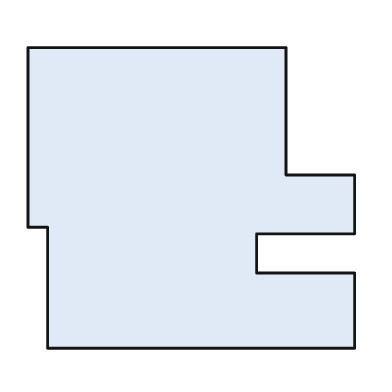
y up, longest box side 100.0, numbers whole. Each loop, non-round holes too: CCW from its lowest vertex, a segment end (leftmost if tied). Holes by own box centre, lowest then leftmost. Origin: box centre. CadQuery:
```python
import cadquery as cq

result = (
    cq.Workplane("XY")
    .moveTo(-44.0, -46.0)
    .lineTo(50.0, -46.0)
    .lineTo(50.0, -23.0)
    .lineTo(20.0, -23.0)
    .lineTo(20.0, -11.0)
    .lineTo(50.0, -11.0)
    .lineTo(50.0, 7.0)
    .lineTo(29.0, 7.0)
    .lineTo(29.0, 46.0)
    .lineTo(-50.0, 46.0)
    .lineTo(-50.0, -9.0)
    .lineTo(-44.0, -9.0)
    .close()
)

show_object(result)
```